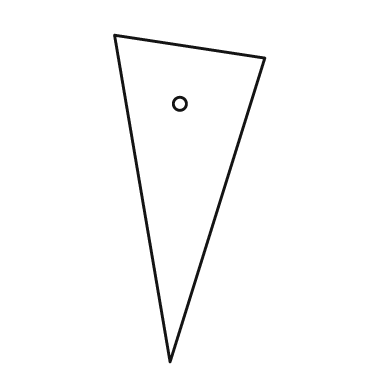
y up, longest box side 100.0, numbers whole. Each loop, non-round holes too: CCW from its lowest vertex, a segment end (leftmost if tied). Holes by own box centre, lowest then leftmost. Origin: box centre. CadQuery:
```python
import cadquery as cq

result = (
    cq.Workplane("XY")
    .moveTo(-6.0, -50.0)
    .lineTo(23.0, 43.0)
    .lineTo(-23.0, 50.0)
    .close()
    .moveTo(-3.0, 29.0)
    .circle(2.0)
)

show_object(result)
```